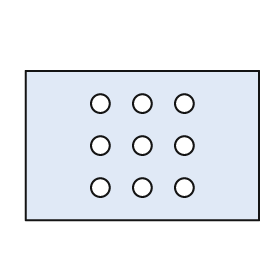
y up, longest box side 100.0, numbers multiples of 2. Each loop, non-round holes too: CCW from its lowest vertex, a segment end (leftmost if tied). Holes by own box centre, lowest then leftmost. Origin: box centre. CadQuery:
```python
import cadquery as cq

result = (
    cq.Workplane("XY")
    .moveTo(-50.0, -32.0)
    .lineTo(50.0, -32.0)
    .lineTo(50.0, 32.0)
    .lineTo(-50.0, 32.0)
    .close()
    .moveTo(-18.0, -18.0)
    .circle(4.0)
    .moveTo(0.0, -18.0)
    .circle(4.0)
    .moveTo(18.0, -18.0)
    .circle(4.0)
    .moveTo(-18.0, 0.0)
    .circle(4.0)
    .moveTo(0.0, 0.0)
    .circle(4.0)
    .moveTo(18.0, 0.0)
    .circle(4.0)
    .moveTo(-18.0, 18.0)
    .circle(4.0)
    .moveTo(0.0, 18.0)
    .circle(4.0)
    .moveTo(18.0, 18.0)
    .circle(4.0)
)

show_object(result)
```